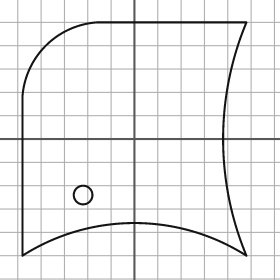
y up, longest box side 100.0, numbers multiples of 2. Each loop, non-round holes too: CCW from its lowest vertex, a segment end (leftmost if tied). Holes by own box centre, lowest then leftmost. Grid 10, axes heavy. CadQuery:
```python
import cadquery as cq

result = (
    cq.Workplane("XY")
    .moveTo(-48.0, -50.0)
    .threePointArc((0.0, -36.0), (48.0, -50.0))
    .threePointArc((38.0, 0.0), (48.0, 50.0))
    .lineTo(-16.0, 50.0)
    .threePointArc((-38.0, 40.0), (-48.0, 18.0))
    .close()
    .moveTo(-22.0, -24.0)
    .circle(4.0)
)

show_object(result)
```